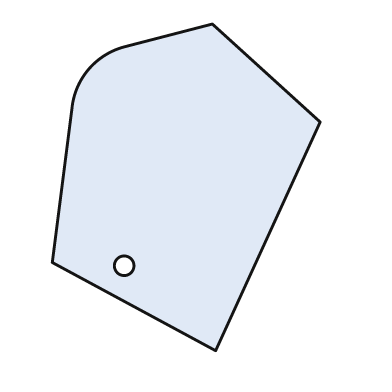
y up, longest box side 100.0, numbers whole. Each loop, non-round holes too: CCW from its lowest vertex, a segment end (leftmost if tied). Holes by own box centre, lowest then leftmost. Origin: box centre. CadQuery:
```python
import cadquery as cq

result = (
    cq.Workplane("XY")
    .moveTo(9.0, -50.0)
    .lineTo(41.0, 20.0)
    .lineTo(8.0, 50.0)
    .lineTo(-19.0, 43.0)
    .threePointArc((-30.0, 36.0), (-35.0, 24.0))
    .lineTo(-41.0, -23.0)
    .close()
    .moveTo(-19.0, -24.0)
    .circle(3.0)
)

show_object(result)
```